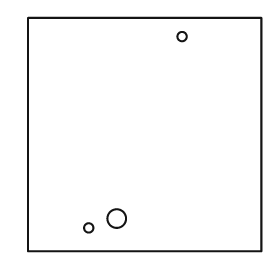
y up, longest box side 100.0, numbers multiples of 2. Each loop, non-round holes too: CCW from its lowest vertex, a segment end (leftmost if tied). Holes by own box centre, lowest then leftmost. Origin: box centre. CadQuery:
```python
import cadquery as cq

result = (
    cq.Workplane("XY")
    .moveTo(-50.0, -50.0)
    .lineTo(50.0, -50.0)
    .lineTo(50.0, 50.0)
    .lineTo(-50.0, 50.0)
    .close()
    .moveTo(-24.0, -40.0)
    .circle(2.0)
    .moveTo(-12.0, -36.0)
    .circle(4.0)
    .moveTo(16.0, 42.0)
    .circle(2.0)
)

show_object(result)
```